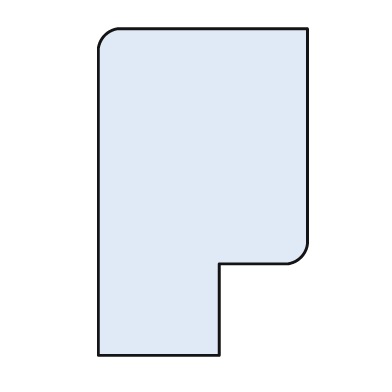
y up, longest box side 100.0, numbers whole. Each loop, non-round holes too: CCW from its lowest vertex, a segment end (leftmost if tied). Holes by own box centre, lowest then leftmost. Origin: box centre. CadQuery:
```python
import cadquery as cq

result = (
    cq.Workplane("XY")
    .moveTo(-32.0, -50.0)
    .lineTo(5.0, -50.0)
    .lineTo(5.0, -22.0)
    .lineTo(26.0, -22.0)
    .threePointArc((30.0, -20.0), (32.0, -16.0))
    .lineTo(32.0, 50.0)
    .lineTo(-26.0, 50.0)
    .threePointArc((-30.0, 48.0), (-32.0, 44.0))
    .close()
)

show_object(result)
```